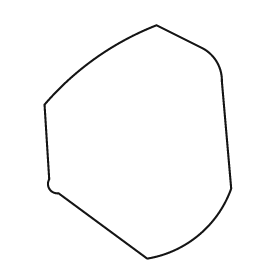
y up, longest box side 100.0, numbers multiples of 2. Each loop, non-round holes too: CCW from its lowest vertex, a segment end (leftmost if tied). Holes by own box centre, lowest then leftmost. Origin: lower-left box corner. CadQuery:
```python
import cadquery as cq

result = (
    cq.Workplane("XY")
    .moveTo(44.0, 0.0)
    .threePointArc((66.0, 10.0), (80.0, 30.0))
    .lineTo(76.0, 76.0)
    .threePointArc((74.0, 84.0), (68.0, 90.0))
    .lineTo(48.0, 100.0)
    .threePointArc((22.0, 86.0), (0.0, 66.0))
    .lineTo(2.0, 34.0)
    .threePointArc((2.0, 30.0), (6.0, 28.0))
    .close()
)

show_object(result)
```